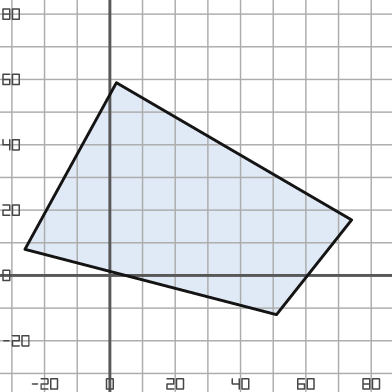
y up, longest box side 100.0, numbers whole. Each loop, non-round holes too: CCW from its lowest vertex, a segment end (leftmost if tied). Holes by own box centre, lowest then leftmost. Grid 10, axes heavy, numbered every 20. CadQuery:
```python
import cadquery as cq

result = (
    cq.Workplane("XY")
    .moveTo(51.0, -12.0)
    .lineTo(74.0, 17.0)
    .lineTo(2.0, 59.0)
    .lineTo(-26.0, 8.0)
    .close()
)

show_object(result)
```